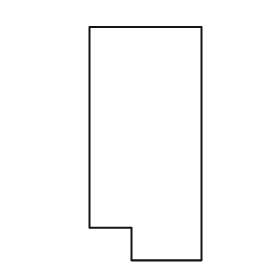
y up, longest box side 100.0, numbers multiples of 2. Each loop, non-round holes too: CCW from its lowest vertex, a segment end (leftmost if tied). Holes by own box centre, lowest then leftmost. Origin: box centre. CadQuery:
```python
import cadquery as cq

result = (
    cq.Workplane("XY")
    .moveTo(-6.0, -50.0)
    .lineTo(24.0, -50.0)
    .lineTo(24.0, 50.0)
    .lineTo(-24.0, 50.0)
    .lineTo(-24.0, -36.0)
    .lineTo(-6.0, -36.0)
    .close()
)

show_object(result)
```